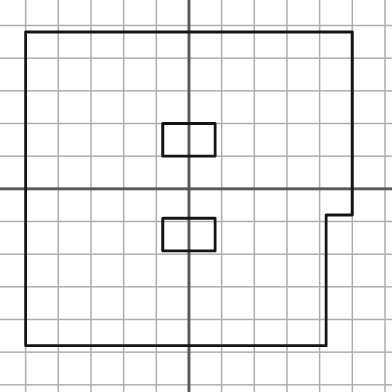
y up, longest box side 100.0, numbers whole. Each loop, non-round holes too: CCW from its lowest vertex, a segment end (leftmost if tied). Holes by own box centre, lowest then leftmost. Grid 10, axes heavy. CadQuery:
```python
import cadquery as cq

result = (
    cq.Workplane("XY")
    .moveTo(-50.0, -48.0)
    .lineTo(42.0, -48.0)
    .lineTo(42.0, -8.0)
    .lineTo(50.0, -8.0)
    .lineTo(50.0, 48.0)
    .lineTo(-50.0, 48.0)
    .close()
    .moveTo(-8.0, -19.0)
    .lineTo(8.0, -19.0)
    .lineTo(8.0, -9.0)
    .lineTo(-8.0, -9.0)
    .close()
    .moveTo(-8.0, 10.0)
    .lineTo(8.0, 10.0)
    .lineTo(8.0, 20.0)
    .lineTo(-8.0, 20.0)
    .close()
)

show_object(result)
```